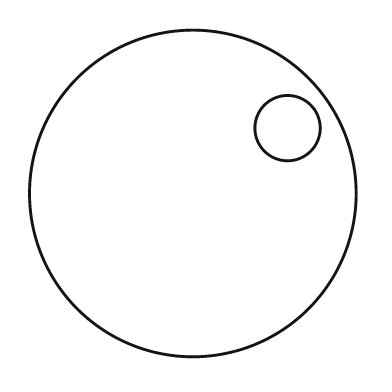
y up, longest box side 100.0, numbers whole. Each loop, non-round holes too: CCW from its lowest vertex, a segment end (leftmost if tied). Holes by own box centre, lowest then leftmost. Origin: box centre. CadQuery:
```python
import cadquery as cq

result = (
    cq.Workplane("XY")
    .moveTo(0.0, 0.0)
    .circle(50.0)
    .moveTo(29.0, 20.0)
    .circle(10.0)
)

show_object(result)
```